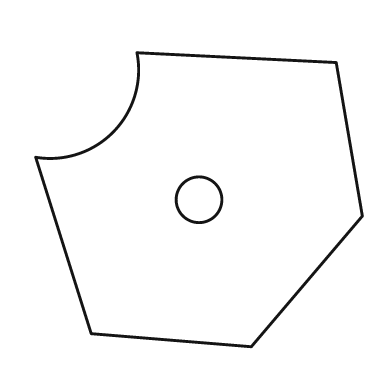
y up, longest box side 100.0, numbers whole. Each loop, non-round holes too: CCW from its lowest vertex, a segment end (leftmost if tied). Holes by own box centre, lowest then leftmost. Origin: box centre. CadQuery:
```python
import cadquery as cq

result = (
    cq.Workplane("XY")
    .moveTo(16.0, -45.0)
    .lineTo(50.0, -5.0)
    .lineTo(42.0, 42.0)
    .lineTo(-19.0, 45.0)
    .threePointArc((-26.0, 21.0), (-50.0, 13.0))
    .lineTo(-33.0, -41.0)
    .close()
    .moveTo(0.0, 0.0)
    .circle(7.0)
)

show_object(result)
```